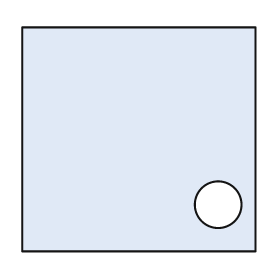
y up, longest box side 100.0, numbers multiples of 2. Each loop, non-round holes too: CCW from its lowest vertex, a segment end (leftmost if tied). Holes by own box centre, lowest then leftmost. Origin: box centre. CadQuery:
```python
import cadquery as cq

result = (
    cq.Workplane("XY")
    .moveTo(-50.0, -48.0)
    .lineTo(50.0, -48.0)
    .lineTo(50.0, 48.0)
    .lineTo(-50.0, 48.0)
    .close()
    .moveTo(34.0, -28.0)
    .circle(10.0)
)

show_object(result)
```